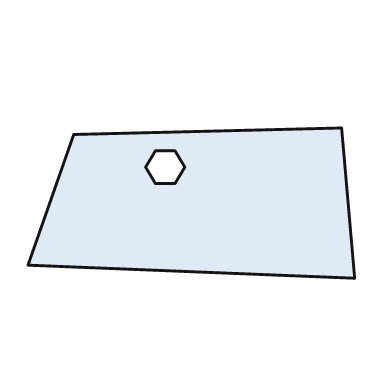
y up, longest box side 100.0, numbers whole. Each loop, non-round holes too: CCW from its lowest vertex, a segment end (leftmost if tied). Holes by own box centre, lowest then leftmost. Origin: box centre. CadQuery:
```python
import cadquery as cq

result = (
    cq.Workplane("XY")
    .moveTo(50.0, -23.0)
    .lineTo(46.0, 23.0)
    .lineTo(-36.0, 21.0)
    .lineTo(-50.0, -19.0)
    .close()
    .moveTo(-11.0, 6.0)
    .lineTo(-5.0, 6.0)
    .lineTo(-2.0, 11.0)
    .lineTo(-5.0, 16.0)
    .lineTo(-11.0, 16.0)
    .lineTo(-14.0, 11.0)
    .close()
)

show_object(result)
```